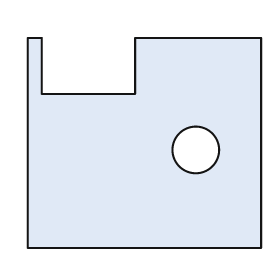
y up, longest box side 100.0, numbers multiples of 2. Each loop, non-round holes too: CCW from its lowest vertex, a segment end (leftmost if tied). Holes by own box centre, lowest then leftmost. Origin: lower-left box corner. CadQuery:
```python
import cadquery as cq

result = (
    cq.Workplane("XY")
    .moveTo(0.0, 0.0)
    .lineTo(100.0, 0.0)
    .lineTo(100.0, 90.0)
    .lineTo(46.0, 90.0)
    .lineTo(46.0, 66.0)
    .lineTo(6.0, 66.0)
    .lineTo(6.0, 90.0)
    .lineTo(0.0, 90.0)
    .close()
    .moveTo(72.0, 42.0)
    .circle(10.0)
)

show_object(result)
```